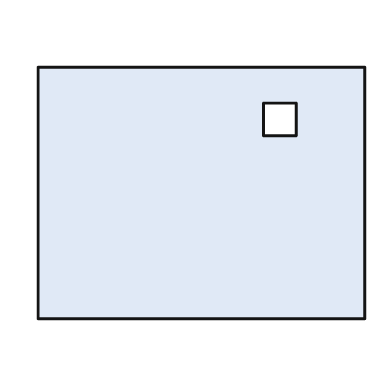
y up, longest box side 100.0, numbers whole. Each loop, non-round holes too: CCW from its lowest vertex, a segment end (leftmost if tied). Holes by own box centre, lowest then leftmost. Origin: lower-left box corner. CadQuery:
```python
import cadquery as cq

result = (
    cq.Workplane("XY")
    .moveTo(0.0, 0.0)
    .lineTo(100.0, 0.0)
    .lineTo(100.0, 77.0)
    .lineTo(0.0, 77.0)
    .close()
    .moveTo(69.0, 56.0)
    .lineTo(79.0, 56.0)
    .lineTo(79.0, 66.0)
    .lineTo(69.0, 66.0)
    .close()
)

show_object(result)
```